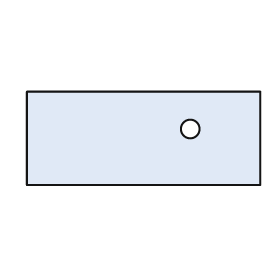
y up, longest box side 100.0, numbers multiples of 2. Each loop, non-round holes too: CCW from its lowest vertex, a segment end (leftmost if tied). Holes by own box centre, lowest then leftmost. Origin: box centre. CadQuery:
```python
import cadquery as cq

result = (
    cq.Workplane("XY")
    .moveTo(-50.0, -20.0)
    .lineTo(50.0, -20.0)
    .lineTo(50.0, 20.0)
    .lineTo(-50.0, 20.0)
    .close()
    .moveTo(20.0, 4.0)
    .circle(4.0)
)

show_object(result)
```